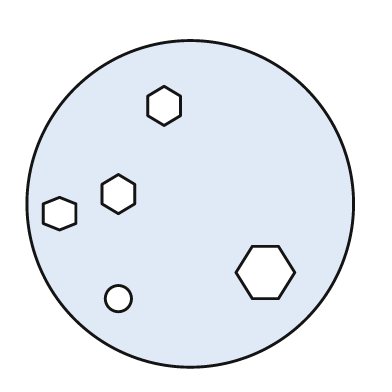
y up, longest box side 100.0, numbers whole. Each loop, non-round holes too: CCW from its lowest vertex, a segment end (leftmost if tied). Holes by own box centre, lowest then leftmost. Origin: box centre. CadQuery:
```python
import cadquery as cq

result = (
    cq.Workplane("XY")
    .moveTo(0.0, 0.0)
    .circle(50.0)
    .moveTo(-22.0, -29.0)
    .circle(4.0)
    .moveTo(19.0, -29.0)
    .lineTo(27.0, -29.0)
    .lineTo(32.0, -21.0)
    .lineTo(27.0, -13.0)
    .lineTo(19.0, -13.0)
    .lineTo(14.0, -21.0)
    .close()
    .moveTo(-40.0, -8.0)
    .lineTo(-35.0, -6.0)
    .lineTo(-35.0, 0.0)
    .lineTo(-40.0, 2.0)
    .lineTo(-45.0, 0.0)
    .lineTo(-45.0, -6.0)
    .close()
    .moveTo(-22.0, -3.0)
    .lineTo(-17.0, 0.0)
    .lineTo(-17.0, 6.0)
    .lineTo(-22.0, 9.0)
    .lineTo(-27.0, 6.0)
    .lineTo(-27.0, 0.0)
    .close()
    .moveTo(-8.0, 24.0)
    .lineTo(-3.0, 27.0)
    .lineTo(-3.0, 33.0)
    .lineTo(-8.0, 36.0)
    .lineTo(-13.0, 33.0)
    .lineTo(-13.0, 27.0)
    .close()
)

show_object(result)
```